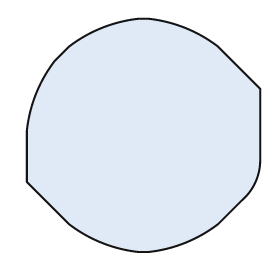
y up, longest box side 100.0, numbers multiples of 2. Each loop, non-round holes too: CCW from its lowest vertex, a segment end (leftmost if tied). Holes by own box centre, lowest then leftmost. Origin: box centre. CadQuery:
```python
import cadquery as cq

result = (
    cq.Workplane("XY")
    .moveTo(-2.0, -50.0)
    .lineTo(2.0, -50.0)
    .threePointArc((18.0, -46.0), (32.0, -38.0))
    .lineTo(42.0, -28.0)
    .threePointArc((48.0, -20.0), (50.0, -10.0))
    .lineTo(50.0, 20.0)
    .lineTo(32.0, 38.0)
    .threePointArc((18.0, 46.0), (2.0, 50.0))
    .lineTo(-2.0, 50.0)
    .threePointArc((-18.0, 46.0), (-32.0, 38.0))
    .lineTo(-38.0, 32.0)
    .threePointArc((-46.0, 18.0), (-50.0, 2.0))
    .lineTo(-50.0, -20.0)
    .lineTo(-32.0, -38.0)
    .threePointArc((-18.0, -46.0), (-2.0, -50.0))
    .close()
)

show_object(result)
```